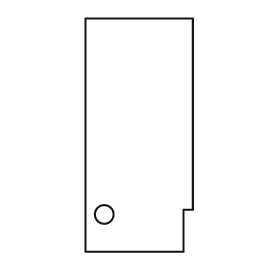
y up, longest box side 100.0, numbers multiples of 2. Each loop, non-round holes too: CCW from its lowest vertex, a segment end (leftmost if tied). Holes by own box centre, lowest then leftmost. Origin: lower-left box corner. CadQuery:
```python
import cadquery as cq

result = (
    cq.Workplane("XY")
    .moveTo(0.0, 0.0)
    .lineTo(42.0, 0.0)
    .lineTo(42.0, 18.0)
    .lineTo(46.0, 18.0)
    .lineTo(46.0, 100.0)
    .lineTo(0.0, 100.0)
    .close()
    .moveTo(8.0, 16.0)
    .circle(4.0)
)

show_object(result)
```